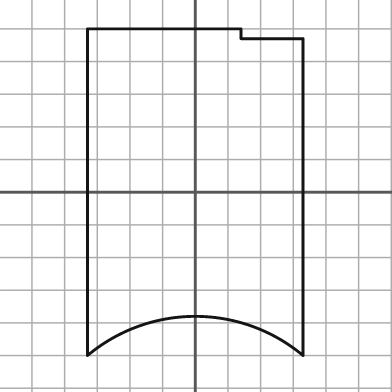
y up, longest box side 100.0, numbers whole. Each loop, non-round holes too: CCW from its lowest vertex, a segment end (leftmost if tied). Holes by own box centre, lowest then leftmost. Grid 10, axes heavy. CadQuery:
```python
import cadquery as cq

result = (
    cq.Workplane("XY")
    .moveTo(-33.0, -50.0)
    .threePointArc((0.0, -38.0), (33.0, -50.0))
    .lineTo(33.0, 47.0)
    .lineTo(14.0, 47.0)
    .lineTo(14.0, 50.0)
    .lineTo(-33.0, 50.0)
    .close()
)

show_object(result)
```